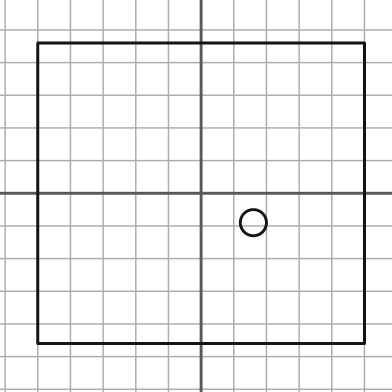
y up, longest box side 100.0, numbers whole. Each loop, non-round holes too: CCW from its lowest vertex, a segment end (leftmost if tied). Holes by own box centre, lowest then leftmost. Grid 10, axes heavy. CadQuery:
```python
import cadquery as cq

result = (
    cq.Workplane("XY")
    .moveTo(-50.0, -46.0)
    .lineTo(50.0, -46.0)
    .lineTo(50.0, 46.0)
    .lineTo(-50.0, 46.0)
    .close()
    .moveTo(16.0, -9.0)
    .circle(4.0)
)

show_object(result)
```